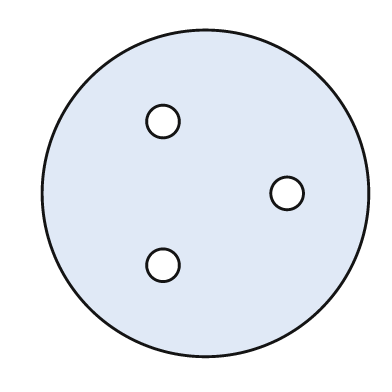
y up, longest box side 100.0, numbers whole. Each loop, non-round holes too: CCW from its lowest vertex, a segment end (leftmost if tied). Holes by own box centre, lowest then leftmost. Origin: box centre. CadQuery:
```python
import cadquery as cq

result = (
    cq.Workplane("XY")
    .moveTo(0.0, 0.0)
    .circle(50.0)
    .moveTo(-13.0, -22.0)
    .circle(5.0)
    .moveTo(25.0, 0.0)
    .circle(5.0)
    .moveTo(-13.0, 22.0)
    .circle(5.0)
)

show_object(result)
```